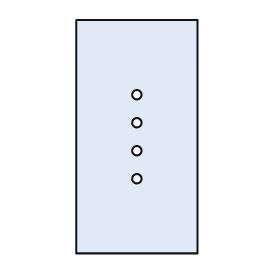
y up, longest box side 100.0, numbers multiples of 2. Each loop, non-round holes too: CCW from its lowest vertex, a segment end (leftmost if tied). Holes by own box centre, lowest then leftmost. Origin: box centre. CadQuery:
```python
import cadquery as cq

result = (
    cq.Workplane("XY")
    .moveTo(-26.0, -50.0)
    .lineTo(26.0, -50.0)
    .lineTo(26.0, 50.0)
    .lineTo(-26.0, 50.0)
    .close()
    .moveTo(0.0, -18.0)
    .circle(2.0)
    .moveTo(0.0, -6.0)
    .circle(2.0)
    .moveTo(0.0, 6.0)
    .circle(2.0)
    .moveTo(0.0, 18.0)
    .circle(2.0)
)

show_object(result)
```